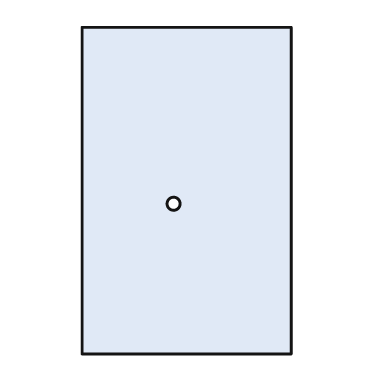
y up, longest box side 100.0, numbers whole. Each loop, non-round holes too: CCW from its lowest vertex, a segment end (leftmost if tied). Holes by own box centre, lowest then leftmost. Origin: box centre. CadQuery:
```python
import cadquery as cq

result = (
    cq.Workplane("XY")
    .moveTo(-32.0, -50.0)
    .lineTo(32.0, -50.0)
    .lineTo(32.0, 50.0)
    .lineTo(-32.0, 50.0)
    .close()
    .moveTo(-4.0, -4.0)
    .circle(2.0)
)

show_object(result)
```